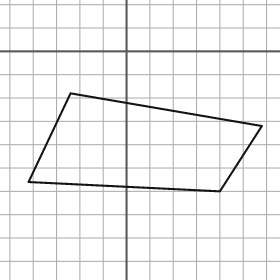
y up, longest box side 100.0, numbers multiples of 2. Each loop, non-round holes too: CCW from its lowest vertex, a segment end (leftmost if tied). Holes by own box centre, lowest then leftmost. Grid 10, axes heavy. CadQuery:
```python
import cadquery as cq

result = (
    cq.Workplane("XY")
    .moveTo(40.0, -60.0)
    .lineTo(58.0, -32.0)
    .lineTo(-24.0, -18.0)
    .lineTo(-42.0, -56.0)
    .close()
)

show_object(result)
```